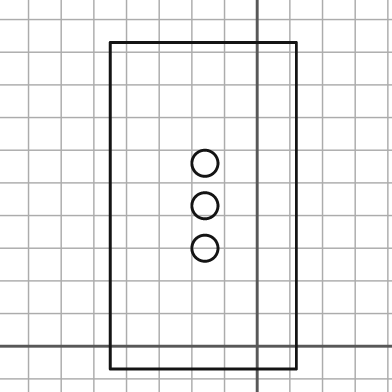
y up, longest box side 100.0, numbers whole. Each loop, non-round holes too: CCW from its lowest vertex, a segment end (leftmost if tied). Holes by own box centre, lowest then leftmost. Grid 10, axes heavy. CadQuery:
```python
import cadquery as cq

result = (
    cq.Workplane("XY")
    .moveTo(-45.0, -7.0)
    .lineTo(12.0, -7.0)
    .lineTo(12.0, 93.0)
    .lineTo(-45.0, 93.0)
    .close()
    .moveTo(-16.0, 30.0)
    .circle(4.0)
    .moveTo(-16.0, 43.0)
    .circle(4.0)
    .moveTo(-16.0, 56.0)
    .circle(4.0)
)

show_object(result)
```